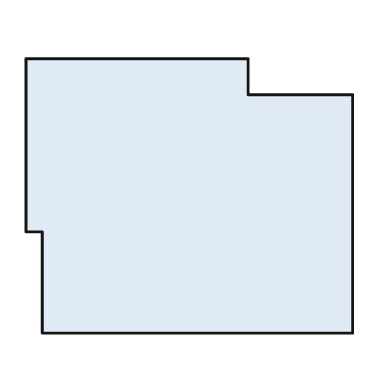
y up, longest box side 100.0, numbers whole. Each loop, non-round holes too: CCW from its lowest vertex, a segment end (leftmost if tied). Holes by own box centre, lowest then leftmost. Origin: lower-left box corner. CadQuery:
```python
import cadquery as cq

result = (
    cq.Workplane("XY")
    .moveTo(5.0, 0.0)
    .lineTo(100.0, 0.0)
    .lineTo(100.0, 73.0)
    .lineTo(68.0, 73.0)
    .lineTo(68.0, 84.0)
    .lineTo(0.0, 84.0)
    .lineTo(0.0, 31.0)
    .lineTo(5.0, 31.0)
    .close()
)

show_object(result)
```